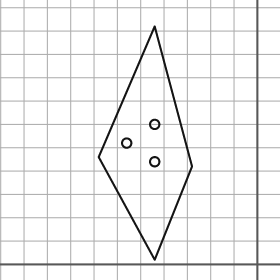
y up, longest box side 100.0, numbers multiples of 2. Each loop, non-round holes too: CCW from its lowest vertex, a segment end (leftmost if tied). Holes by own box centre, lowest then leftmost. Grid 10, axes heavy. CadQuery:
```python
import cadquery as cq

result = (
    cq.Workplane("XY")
    .moveTo(-44.0, 2.0)
    .lineTo(-28.0, 42.0)
    .lineTo(-44.0, 102.0)
    .lineTo(-68.0, 46.0)
    .close()
    .moveTo(-44.0, 44.0)
    .circle(2.0)
    .moveTo(-56.0, 52.0)
    .circle(2.0)
    .moveTo(-44.0, 60.0)
    .circle(2.0)
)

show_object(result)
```